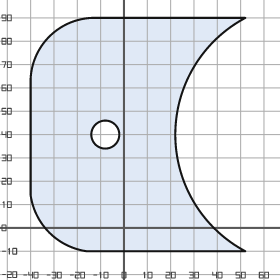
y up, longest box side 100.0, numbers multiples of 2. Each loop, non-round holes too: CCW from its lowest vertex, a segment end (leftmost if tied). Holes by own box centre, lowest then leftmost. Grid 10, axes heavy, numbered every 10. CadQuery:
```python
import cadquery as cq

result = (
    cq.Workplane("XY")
    .moveTo(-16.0, -10.0)
    .lineTo(52.0, -10.0)
    .threePointArc((22.0, 40.0), (52.0, 90.0))
    .lineTo(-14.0, 90.0)
    .threePointArc((-32.0, 82.0), (-40.0, 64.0))
    .lineTo(-40.0, 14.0)
    .threePointArc((-32.0, -2.0), (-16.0, -10.0))
    .close()
    .moveTo(-8.0, 40.0)
    .circle(6.0)
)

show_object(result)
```